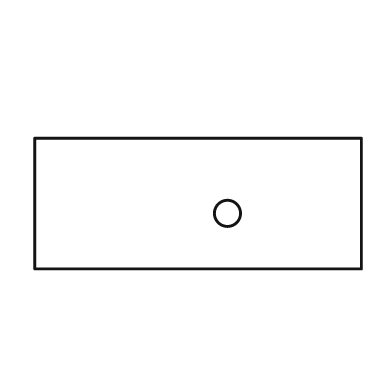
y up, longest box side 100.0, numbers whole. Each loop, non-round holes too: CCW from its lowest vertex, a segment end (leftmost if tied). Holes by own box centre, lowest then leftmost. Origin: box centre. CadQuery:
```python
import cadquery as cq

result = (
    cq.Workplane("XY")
    .moveTo(-50.0, -20.0)
    .lineTo(50.0, -20.0)
    .lineTo(50.0, 20.0)
    .lineTo(-50.0, 20.0)
    .close()
    .moveTo(9.0, -3.0)
    .circle(4.0)
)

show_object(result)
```